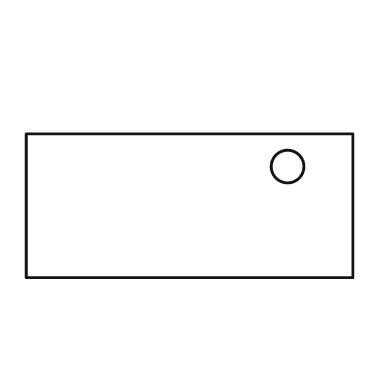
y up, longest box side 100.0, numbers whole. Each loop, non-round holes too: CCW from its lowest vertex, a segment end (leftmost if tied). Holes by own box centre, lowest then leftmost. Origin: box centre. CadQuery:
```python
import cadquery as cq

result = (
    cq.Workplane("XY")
    .moveTo(-50.0, -22.0)
    .lineTo(50.0, -22.0)
    .lineTo(50.0, 22.0)
    .lineTo(-50.0, 22.0)
    .close()
    .moveTo(30.0, 12.0)
    .circle(5.0)
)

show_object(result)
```